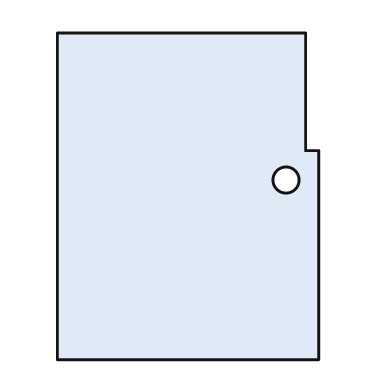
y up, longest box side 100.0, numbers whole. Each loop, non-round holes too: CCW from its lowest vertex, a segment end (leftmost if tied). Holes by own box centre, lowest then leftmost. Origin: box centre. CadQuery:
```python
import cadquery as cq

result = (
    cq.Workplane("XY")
    .moveTo(-40.0, -50.0)
    .lineTo(40.0, -50.0)
    .lineTo(40.0, 14.0)
    .lineTo(36.0, 14.0)
    .lineTo(36.0, 50.0)
    .lineTo(-40.0, 50.0)
    .close()
    .moveTo(30.0, 5.0)
    .circle(4.0)
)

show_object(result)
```